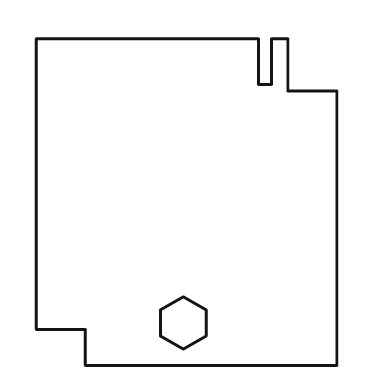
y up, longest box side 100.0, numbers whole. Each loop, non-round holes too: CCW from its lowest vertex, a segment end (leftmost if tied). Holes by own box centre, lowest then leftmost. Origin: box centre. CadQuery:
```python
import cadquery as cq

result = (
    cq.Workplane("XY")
    .moveTo(-31.0, -50.0)
    .lineTo(46.0, -50.0)
    .lineTo(46.0, 34.0)
    .lineTo(31.0, 34.0)
    .lineTo(31.0, 50.0)
    .lineTo(26.0, 50.0)
    .lineTo(26.0, 36.0)
    .lineTo(22.0, 36.0)
    .lineTo(22.0, 50.0)
    .lineTo(-46.0, 50.0)
    .lineTo(-46.0, -39.0)
    .lineTo(-31.0, -39.0)
    .close()
    .moveTo(-1.0, -45.0)
    .lineTo(6.0, -41.0)
    .lineTo(6.0, -33.0)
    .lineTo(-1.0, -29.0)
    .lineTo(-8.0, -33.0)
    .lineTo(-8.0, -41.0)
    .close()
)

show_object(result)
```